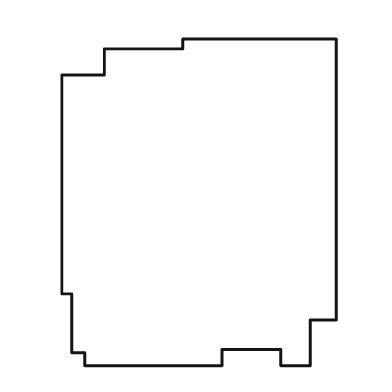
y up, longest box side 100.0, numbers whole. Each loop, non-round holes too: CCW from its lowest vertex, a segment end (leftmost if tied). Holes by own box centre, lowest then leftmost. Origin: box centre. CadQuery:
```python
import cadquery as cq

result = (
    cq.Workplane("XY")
    .moveTo(-35.0, -50.0)
    .lineTo(7.0, -50.0)
    .lineTo(7.0, -45.0)
    .lineTo(25.0, -45.0)
    .lineTo(25.0, -50.0)
    .lineTo(34.0, -50.0)
    .lineTo(34.0, -36.0)
    .lineTo(42.0, -36.0)
    .lineTo(42.0, 50.0)
    .lineTo(-5.0, 50.0)
    .lineTo(-5.0, 47.0)
    .lineTo(-29.0, 47.0)
    .lineTo(-29.0, 39.0)
    .lineTo(-42.0, 39.0)
    .lineTo(-42.0, -28.0)
    .lineTo(-39.0, -28.0)
    .lineTo(-39.0, -46.0)
    .lineTo(-35.0, -46.0)
    .close()
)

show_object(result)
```